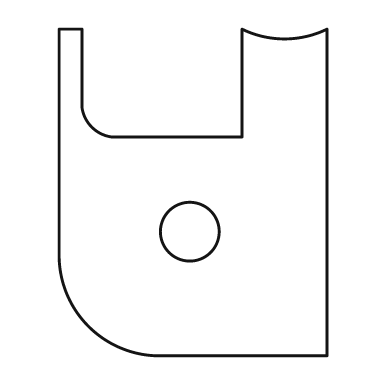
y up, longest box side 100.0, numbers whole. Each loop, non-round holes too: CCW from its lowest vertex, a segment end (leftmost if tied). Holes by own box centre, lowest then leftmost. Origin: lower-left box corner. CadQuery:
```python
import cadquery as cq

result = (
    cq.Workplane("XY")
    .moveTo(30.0, 0.0)
    .lineTo(82.0, 0.0)
    .lineTo(82.0, 100.0)
    .threePointArc((69.0, 97.0), (56.0, 100.0))
    .lineTo(56.0, 67.0)
    .lineTo(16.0, 67.0)
    .threePointArc((10.0, 70.0), (7.0, 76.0))
    .lineTo(7.0, 100.0)
    .lineTo(0.0, 100.0)
    .lineTo(0.0, 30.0)
    .threePointArc((9.0, 9.0), (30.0, 0.0))
    .close()
    .moveTo(40.0, 38.0)
    .circle(9.0)
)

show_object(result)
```